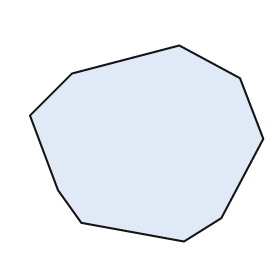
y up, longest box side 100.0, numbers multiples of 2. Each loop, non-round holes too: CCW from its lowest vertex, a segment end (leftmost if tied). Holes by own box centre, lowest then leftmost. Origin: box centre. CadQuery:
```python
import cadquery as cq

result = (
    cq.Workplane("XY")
    .moveTo(16.0, -42.0)
    .lineTo(32.0, -32.0)
    .lineTo(50.0, 2.0)
    .lineTo(40.0, 28.0)
    .lineTo(14.0, 42.0)
    .lineTo(-32.0, 30.0)
    .lineTo(-50.0, 12.0)
    .lineTo(-38.0, -20.0)
    .lineTo(-28.0, -34.0)
    .close()
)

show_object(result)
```